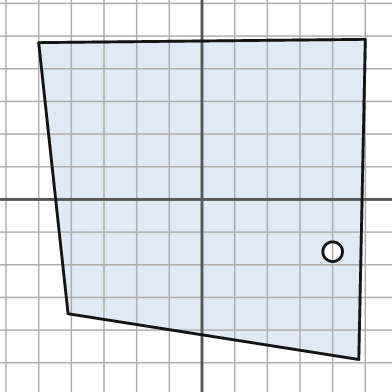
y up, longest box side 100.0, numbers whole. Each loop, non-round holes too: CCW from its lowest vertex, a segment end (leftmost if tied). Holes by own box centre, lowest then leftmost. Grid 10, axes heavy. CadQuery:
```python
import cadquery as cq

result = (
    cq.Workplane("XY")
    .moveTo(48.0, -49.0)
    .lineTo(50.0, 49.0)
    .lineTo(-50.0, 48.0)
    .lineTo(-41.0, -35.0)
    .close()
    .moveTo(40.0, -16.0)
    .circle(3.0)
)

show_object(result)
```